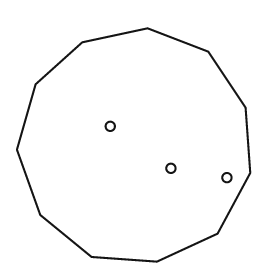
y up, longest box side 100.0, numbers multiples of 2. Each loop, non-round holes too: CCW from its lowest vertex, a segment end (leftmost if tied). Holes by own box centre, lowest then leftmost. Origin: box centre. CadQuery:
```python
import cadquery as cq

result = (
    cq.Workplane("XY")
    .moveTo(10.0, -50.0)
    .lineTo(36.0, -38.0)
    .lineTo(50.0, -12.0)
    .lineTo(48.0, 16.0)
    .lineTo(32.0, 40.0)
    .lineTo(6.0, 50.0)
    .lineTo(-22.0, 44.0)
    .lineTo(-42.0, 26.0)
    .lineTo(-50.0, -2.0)
    .lineTo(-40.0, -30.0)
    .lineTo(-18.0, -48.0)
    .close()
    .moveTo(40.0, -14.0)
    .circle(2.0)
    .moveTo(16.0, -10.0)
    .circle(2.0)
    .moveTo(-10.0, 8.0)
    .circle(2.0)
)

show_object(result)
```